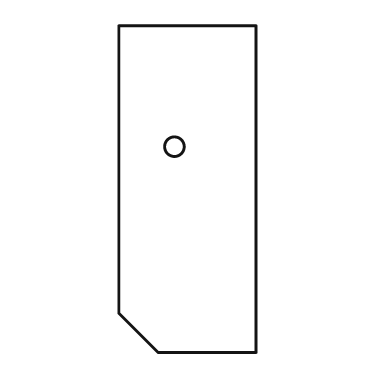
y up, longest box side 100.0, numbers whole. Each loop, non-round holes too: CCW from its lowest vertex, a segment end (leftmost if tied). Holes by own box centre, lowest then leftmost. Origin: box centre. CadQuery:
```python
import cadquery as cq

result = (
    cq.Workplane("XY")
    .moveTo(-9.0, -50.0)
    .lineTo(21.0, -50.0)
    .lineTo(21.0, 50.0)
    .lineTo(-21.0, 50.0)
    .lineTo(-21.0, -38.0)
    .close()
    .moveTo(-4.0, 13.0)
    .circle(3.0)
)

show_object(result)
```